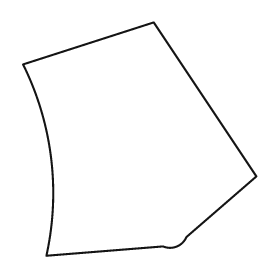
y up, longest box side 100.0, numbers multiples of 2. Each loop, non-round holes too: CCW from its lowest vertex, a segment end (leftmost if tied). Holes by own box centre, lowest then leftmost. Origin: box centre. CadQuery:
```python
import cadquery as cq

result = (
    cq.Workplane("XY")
    .moveTo(-40.0, -50.0)
    .lineTo(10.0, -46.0)
    .threePointArc((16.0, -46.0), (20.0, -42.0))
    .lineTo(50.0, -16.0)
    .lineTo(6.0, 50.0)
    .lineTo(-50.0, 32.0)
    .threePointArc((-38.0, -8.0), (-40.0, -50.0))
    .close()
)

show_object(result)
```